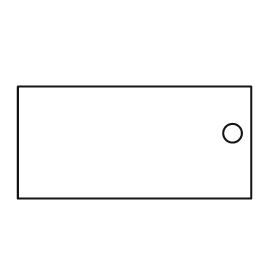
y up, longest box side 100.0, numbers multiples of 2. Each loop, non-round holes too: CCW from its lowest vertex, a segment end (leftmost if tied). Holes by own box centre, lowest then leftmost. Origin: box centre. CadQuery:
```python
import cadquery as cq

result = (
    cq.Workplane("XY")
    .moveTo(-50.0, -24.0)
    .lineTo(50.0, -24.0)
    .lineTo(50.0, 24.0)
    .lineTo(-50.0, 24.0)
    .close()
    .moveTo(42.0, 4.0)
    .circle(4.0)
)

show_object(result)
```